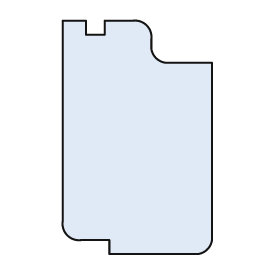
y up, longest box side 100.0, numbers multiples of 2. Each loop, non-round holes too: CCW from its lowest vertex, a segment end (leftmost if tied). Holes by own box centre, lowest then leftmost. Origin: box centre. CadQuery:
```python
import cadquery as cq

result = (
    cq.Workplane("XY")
    .moveTo(-12.0, -50.0)
    .lineTo(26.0, -50.0)
    .threePointArc((30.0, -48.0), (32.0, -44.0))
    .lineTo(32.0, 32.0)
    .lineTo(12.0, 32.0)
    .threePointArc((8.0, 34.0), (6.0, 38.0))
    .lineTo(6.0, 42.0)
    .threePointArc((4.0, 48.0), (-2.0, 50.0))
    .lineTo(-14.0, 50.0)
    .lineTo(-14.0, 44.0)
    .lineTo(-22.0, 44.0)
    .lineTo(-22.0, 50.0)
    .lineTo(-32.0, 50.0)
    .lineTo(-32.0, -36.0)
    .threePointArc((-30.0, -42.0), (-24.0, -44.0))
    .lineTo(-12.0, -44.0)
    .close()
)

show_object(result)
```